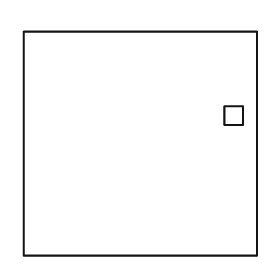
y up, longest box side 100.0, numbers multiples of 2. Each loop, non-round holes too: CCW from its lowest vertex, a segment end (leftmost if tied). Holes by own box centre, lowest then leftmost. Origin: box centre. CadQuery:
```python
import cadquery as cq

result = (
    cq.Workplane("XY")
    .moveTo(-50.0, -48.0)
    .lineTo(50.0, -48.0)
    .lineTo(50.0, 48.0)
    .lineTo(-50.0, 48.0)
    .close()
    .moveTo(36.0, 8.0)
    .lineTo(44.0, 8.0)
    .lineTo(44.0, 16.0)
    .lineTo(36.0, 16.0)
    .close()
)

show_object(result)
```